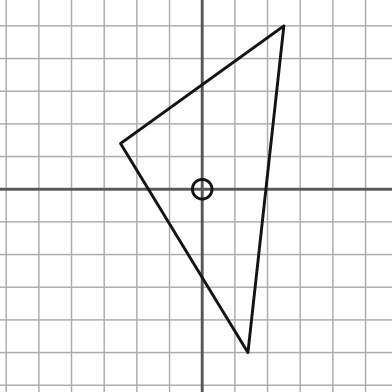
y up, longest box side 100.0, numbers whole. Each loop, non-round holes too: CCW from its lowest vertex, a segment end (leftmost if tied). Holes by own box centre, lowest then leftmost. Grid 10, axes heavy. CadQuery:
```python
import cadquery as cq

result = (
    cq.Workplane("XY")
    .moveTo(14.0, -50.0)
    .lineTo(25.0, 50.0)
    .lineTo(-25.0, 14.0)
    .close()
    .moveTo(0.0, 0.0)
    .circle(3.0)
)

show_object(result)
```